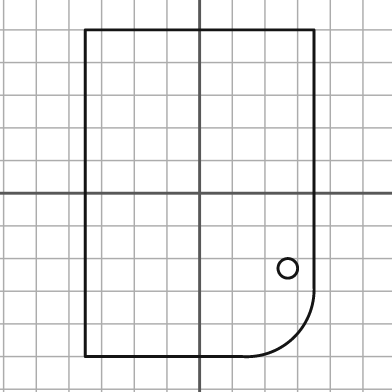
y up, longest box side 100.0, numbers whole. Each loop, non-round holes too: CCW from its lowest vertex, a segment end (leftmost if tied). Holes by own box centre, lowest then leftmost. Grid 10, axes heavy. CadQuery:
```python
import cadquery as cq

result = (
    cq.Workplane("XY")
    .moveTo(-35.0, -50.0)
    .lineTo(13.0, -50.0)
    .threePointArc((29.0, -44.0), (35.0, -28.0))
    .lineTo(35.0, 50.0)
    .lineTo(-35.0, 50.0)
    .close()
    .moveTo(27.0, -23.0)
    .circle(3.0)
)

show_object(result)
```